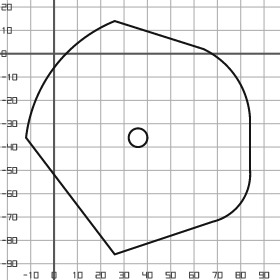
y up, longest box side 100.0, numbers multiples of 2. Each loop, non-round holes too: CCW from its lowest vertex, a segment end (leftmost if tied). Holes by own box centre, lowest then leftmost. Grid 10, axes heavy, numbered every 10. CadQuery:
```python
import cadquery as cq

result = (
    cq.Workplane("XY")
    .moveTo(26.0, -86.0)
    .lineTo(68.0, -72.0)
    .threePointArc((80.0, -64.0), (84.0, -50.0))
    .lineTo(84.0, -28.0)
    .threePointArc((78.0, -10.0), (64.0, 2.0))
    .lineTo(26.0, 14.0)
    .threePointArc((0.0, -6.0), (-12.0, -36.0))
    .close()
    .moveTo(36.0, -36.0)
    .circle(4.0)
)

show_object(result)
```